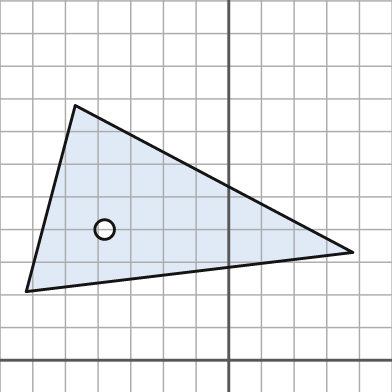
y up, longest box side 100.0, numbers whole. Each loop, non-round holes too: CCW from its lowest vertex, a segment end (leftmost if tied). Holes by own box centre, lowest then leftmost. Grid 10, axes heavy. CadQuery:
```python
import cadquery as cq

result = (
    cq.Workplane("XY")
    .moveTo(-62.0, 21.0)
    .lineTo(38.0, 33.0)
    .lineTo(-47.0, 78.0)
    .close()
    .moveTo(-38.0, 40.0)
    .circle(3.0)
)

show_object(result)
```